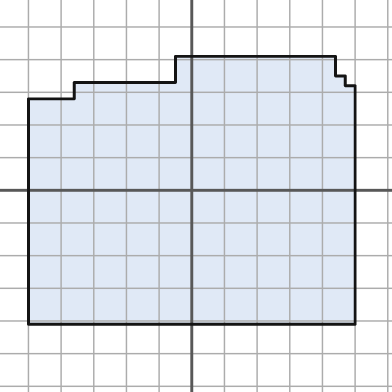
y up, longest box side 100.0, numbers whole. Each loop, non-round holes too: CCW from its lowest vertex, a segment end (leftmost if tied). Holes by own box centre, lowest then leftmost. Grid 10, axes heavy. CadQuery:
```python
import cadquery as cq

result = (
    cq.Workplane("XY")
    .moveTo(-50.0, -41.0)
    .lineTo(50.0, -41.0)
    .lineTo(50.0, 32.0)
    .lineTo(47.0, 32.0)
    .lineTo(47.0, 35.0)
    .lineTo(44.0, 35.0)
    .lineTo(44.0, 41.0)
    .lineTo(-5.0, 41.0)
    .lineTo(-5.0, 33.0)
    .lineTo(-36.0, 33.0)
    .lineTo(-36.0, 28.0)
    .lineTo(-50.0, 28.0)
    .close()
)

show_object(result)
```